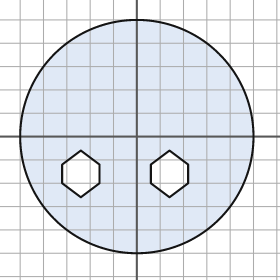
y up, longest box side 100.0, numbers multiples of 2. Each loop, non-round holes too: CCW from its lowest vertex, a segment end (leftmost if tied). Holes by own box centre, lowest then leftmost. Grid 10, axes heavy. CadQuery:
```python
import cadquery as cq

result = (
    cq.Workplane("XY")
    .moveTo(0.0, 0.0)
    .circle(50.0)
    .moveTo(-24.0, -26.0)
    .lineTo(-16.0, -20.0)
    .lineTo(-16.0, -12.0)
    .lineTo(-24.0, -6.0)
    .lineTo(-32.0, -12.0)
    .lineTo(-32.0, -20.0)
    .close()
    .moveTo(14.0, -26.0)
    .lineTo(22.0, -20.0)
    .lineTo(22.0, -12.0)
    .lineTo(14.0, -6.0)
    .lineTo(6.0, -12.0)
    .lineTo(6.0, -20.0)
    .close()
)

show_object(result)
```